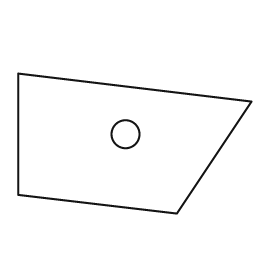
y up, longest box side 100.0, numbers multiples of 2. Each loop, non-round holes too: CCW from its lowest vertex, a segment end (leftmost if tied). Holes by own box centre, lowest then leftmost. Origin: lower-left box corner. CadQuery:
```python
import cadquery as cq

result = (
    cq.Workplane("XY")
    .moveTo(68.0, 0.0)
    .lineTo(100.0, 48.0)
    .lineTo(0.0, 60.0)
    .lineTo(0.0, 8.0)
    .close()
    .moveTo(46.0, 34.0)
    .circle(6.0)
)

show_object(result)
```